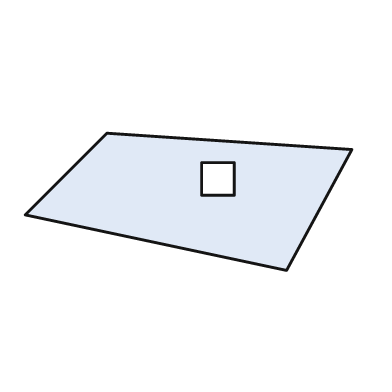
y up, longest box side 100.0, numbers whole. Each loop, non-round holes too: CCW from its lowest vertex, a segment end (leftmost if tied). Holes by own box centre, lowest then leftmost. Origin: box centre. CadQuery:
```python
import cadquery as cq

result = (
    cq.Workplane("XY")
    .moveTo(30.0, -21.0)
    .lineTo(50.0, 16.0)
    .lineTo(-25.0, 21.0)
    .lineTo(-50.0, -4.0)
    .close()
    .moveTo(4.0, 2.0)
    .lineTo(14.0, 2.0)
    .lineTo(14.0, 12.0)
    .lineTo(4.0, 12.0)
    .close()
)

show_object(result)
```